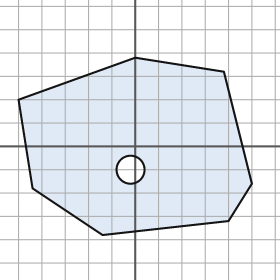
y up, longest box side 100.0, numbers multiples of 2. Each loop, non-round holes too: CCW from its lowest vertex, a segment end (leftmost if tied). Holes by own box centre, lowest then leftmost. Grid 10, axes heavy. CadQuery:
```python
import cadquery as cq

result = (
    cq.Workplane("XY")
    .moveTo(-14.0, -38.0)
    .lineTo(40.0, -32.0)
    .lineTo(50.0, -16.0)
    .lineTo(38.0, 32.0)
    .lineTo(0.0, 38.0)
    .lineTo(-50.0, 20.0)
    .lineTo(-44.0, -18.0)
    .close()
    .moveTo(-2.0, -10.0)
    .circle(6.0)
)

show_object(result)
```